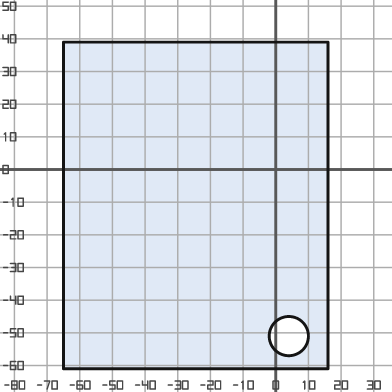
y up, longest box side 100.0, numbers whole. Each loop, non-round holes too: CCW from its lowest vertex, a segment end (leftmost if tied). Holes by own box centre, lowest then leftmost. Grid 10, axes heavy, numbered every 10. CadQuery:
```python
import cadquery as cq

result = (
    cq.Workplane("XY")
    .moveTo(-65.0, -61.0)
    .lineTo(16.0, -61.0)
    .lineTo(16.0, 39.0)
    .lineTo(-65.0, 39.0)
    .close()
    .moveTo(4.0, -51.0)
    .circle(6.0)
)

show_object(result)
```